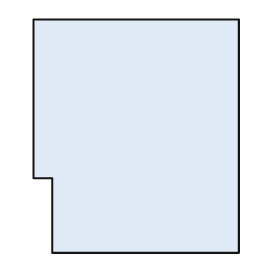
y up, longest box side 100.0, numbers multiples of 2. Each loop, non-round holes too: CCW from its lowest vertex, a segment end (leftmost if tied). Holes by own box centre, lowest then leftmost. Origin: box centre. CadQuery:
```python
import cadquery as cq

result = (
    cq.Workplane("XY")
    .moveTo(-36.0, -50.0)
    .lineTo(44.0, -50.0)
    .lineTo(44.0, 50.0)
    .lineTo(-44.0, 50.0)
    .lineTo(-44.0, -18.0)
    .lineTo(-36.0, -18.0)
    .close()
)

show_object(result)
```